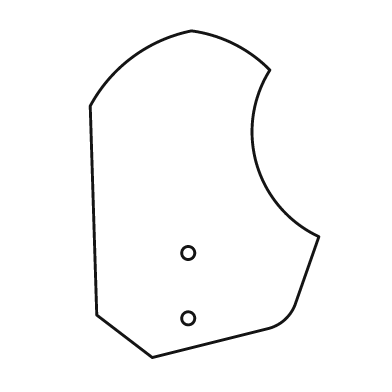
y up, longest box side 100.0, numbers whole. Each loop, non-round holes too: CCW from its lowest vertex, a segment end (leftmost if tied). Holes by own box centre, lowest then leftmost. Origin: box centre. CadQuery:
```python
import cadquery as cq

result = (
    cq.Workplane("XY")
    .moveTo(-16.0, -50.0)
    .lineTo(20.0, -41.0)
    .threePointArc((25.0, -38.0), (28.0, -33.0))
    .lineTo(35.0, -13.0)
    .threePointArc((16.0, 9.0), (20.0, 38.0))
    .threePointArc((9.0, 46.0), (-4.0, 50.0))
    .threePointArc((-22.0, 42.0), (-35.0, 27.0))
    .lineTo(-33.0, -37.0)
    .close()
    .moveTo(-5.0, -38.0)
    .circle(2.0)
    .moveTo(-5.0, -18.0)
    .circle(2.0)
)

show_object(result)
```